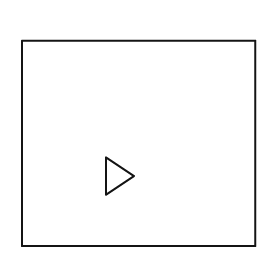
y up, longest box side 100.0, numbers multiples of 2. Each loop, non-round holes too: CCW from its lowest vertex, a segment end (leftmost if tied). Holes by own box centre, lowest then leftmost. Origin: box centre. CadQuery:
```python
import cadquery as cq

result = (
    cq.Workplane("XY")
    .moveTo(-50.0, -44.0)
    .lineTo(50.0, -44.0)
    .lineTo(50.0, 44.0)
    .lineTo(-50.0, 44.0)
    .close()
    .moveTo(-14.0, -22.0)
    .lineTo(-2.0, -14.0)
    .lineTo(-14.0, -6.0)
    .close()
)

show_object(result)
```